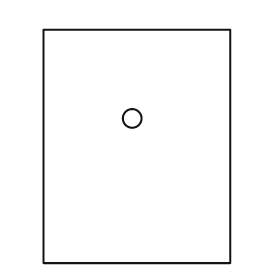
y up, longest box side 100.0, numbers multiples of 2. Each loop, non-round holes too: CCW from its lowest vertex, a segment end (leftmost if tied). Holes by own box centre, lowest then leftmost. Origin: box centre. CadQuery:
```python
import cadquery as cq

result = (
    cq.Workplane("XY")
    .moveTo(-40.0, -50.0)
    .lineTo(40.0, -50.0)
    .lineTo(40.0, 50.0)
    .lineTo(-40.0, 50.0)
    .close()
    .moveTo(-2.0, 12.0)
    .circle(4.0)
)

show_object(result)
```